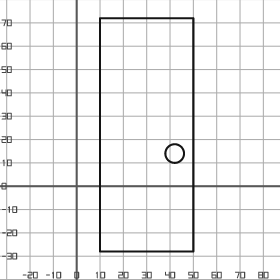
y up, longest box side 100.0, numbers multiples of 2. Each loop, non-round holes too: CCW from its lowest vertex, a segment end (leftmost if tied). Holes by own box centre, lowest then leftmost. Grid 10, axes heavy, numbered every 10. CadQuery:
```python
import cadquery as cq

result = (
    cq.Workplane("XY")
    .moveTo(10.0, -28.0)
    .lineTo(50.0, -28.0)
    .lineTo(50.0, 72.0)
    .lineTo(10.0, 72.0)
    .close()
    .moveTo(42.0, 14.0)
    .circle(4.0)
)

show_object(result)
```